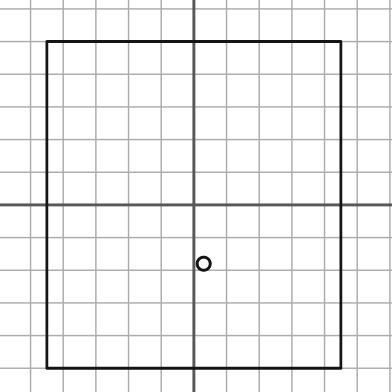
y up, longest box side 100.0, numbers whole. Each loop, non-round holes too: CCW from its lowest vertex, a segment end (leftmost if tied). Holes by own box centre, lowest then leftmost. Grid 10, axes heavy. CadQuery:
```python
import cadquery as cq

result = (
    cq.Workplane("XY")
    .moveTo(-45.0, -50.0)
    .lineTo(45.0, -50.0)
    .lineTo(45.0, 50.0)
    .lineTo(-45.0, 50.0)
    .close()
    .moveTo(3.0, -18.0)
    .circle(2.0)
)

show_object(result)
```